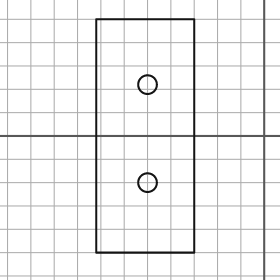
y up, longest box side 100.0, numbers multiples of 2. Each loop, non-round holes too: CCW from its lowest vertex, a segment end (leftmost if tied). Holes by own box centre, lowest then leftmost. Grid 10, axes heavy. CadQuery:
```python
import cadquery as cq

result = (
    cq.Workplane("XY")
    .moveTo(-72.0, -50.0)
    .lineTo(-30.0, -50.0)
    .lineTo(-30.0, 50.0)
    .lineTo(-72.0, 50.0)
    .close()
    .moveTo(-50.0, -20.0)
    .circle(4.0)
    .moveTo(-50.0, 22.0)
    .circle(4.0)
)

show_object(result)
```